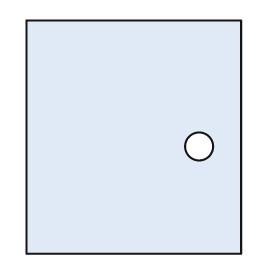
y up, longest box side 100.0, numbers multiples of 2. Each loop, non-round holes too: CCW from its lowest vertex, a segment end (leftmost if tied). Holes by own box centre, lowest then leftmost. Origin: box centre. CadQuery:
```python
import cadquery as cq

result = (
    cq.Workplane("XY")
    .moveTo(-46.0, -50.0)
    .lineTo(46.0, -50.0)
    .lineTo(46.0, 50.0)
    .lineTo(-46.0, 50.0)
    .close()
    .moveTo(28.0, -4.0)
    .circle(6.0)
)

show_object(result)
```